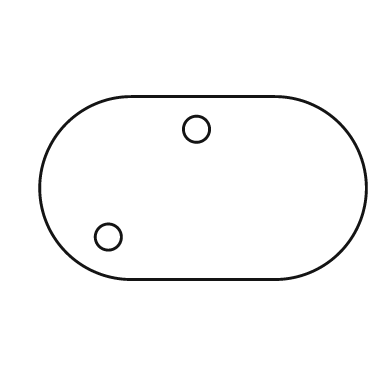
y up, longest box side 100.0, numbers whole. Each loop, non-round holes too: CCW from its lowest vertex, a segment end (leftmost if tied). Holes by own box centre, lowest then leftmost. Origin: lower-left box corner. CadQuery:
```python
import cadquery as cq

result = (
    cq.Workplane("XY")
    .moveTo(28.0, 0.0)
    .lineTo(72.0, 0.0)
    .threePointArc((100.0, 28.0), (72.0, 56.0))
    .lineTo(28.0, 56.0)
    .threePointArc((0.0, 28.0), (28.0, 0.0))
    .close()
    .moveTo(21.0, 13.0)
    .circle(4.0)
    .moveTo(48.0, 46.0)
    .circle(4.0)
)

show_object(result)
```